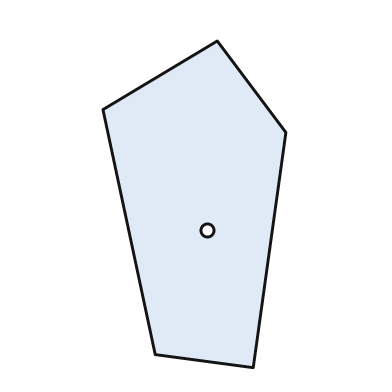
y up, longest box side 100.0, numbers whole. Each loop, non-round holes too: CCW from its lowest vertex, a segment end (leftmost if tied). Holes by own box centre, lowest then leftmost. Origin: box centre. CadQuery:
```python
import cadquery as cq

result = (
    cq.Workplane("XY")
    .moveTo(18.0, -50.0)
    .lineTo(28.0, 22.0)
    .lineTo(7.0, 50.0)
    .lineTo(-28.0, 29.0)
    .lineTo(-12.0, -46.0)
    .close()
    .moveTo(4.0, -8.0)
    .circle(2.0)
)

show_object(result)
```